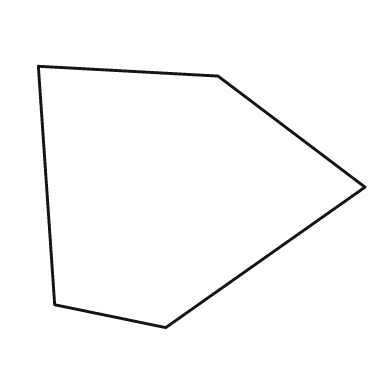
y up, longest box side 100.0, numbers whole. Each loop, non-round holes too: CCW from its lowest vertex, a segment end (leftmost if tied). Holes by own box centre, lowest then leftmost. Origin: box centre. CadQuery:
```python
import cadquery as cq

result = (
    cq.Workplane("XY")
    .moveTo(-11.0, -40.0)
    .lineTo(50.0, 3.0)
    .lineTo(5.0, 37.0)
    .lineTo(-50.0, 40.0)
    .lineTo(-45.0, -33.0)
    .close()
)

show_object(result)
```